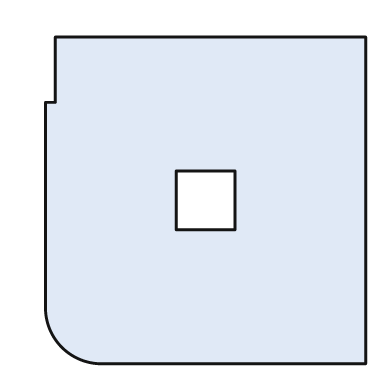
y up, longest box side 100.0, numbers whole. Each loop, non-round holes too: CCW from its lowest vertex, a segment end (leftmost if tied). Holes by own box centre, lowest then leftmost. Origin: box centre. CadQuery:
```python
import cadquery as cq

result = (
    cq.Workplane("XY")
    .moveTo(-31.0, -50.0)
    .lineTo(49.0, -50.0)
    .lineTo(49.0, 50.0)
    .lineTo(-46.0, 50.0)
    .lineTo(-46.0, 30.0)
    .lineTo(-49.0, 30.0)
    .lineTo(-49.0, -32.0)
    .threePointArc((-44.0, -45.0), (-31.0, -50.0))
    .close()
    .moveTo(-9.0, -9.0)
    .lineTo(9.0, -9.0)
    .lineTo(9.0, 9.0)
    .lineTo(-9.0, 9.0)
    .close()
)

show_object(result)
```